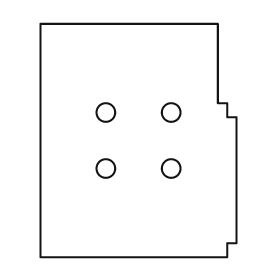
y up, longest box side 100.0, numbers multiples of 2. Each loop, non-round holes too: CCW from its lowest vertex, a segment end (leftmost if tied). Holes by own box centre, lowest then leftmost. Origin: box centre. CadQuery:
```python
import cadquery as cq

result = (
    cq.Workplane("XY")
    .moveTo(-42.0, -50.0)
    .lineTo(38.0, -50.0)
    .lineTo(38.0, -44.0)
    .lineTo(42.0, -44.0)
    .lineTo(42.0, 10.0)
    .lineTo(38.0, 10.0)
    .lineTo(38.0, 16.0)
    .lineTo(34.0, 16.0)
    .lineTo(34.0, 50.0)
    .lineTo(-42.0, 50.0)
    .close()
    .moveTo(-14.0, -12.0)
    .circle(4.0)
    .moveTo(14.0, -12.0)
    .circle(4.0)
    .moveTo(-14.0, 12.0)
    .circle(4.0)
    .moveTo(14.0, 12.0)
    .circle(4.0)
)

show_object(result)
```